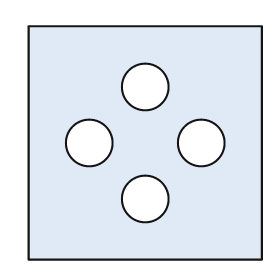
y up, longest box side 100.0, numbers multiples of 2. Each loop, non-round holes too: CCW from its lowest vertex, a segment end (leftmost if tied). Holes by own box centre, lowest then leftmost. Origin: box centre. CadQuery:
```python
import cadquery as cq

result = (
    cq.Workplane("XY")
    .moveTo(-50.0, -50.0)
    .lineTo(50.0, -50.0)
    .lineTo(50.0, 50.0)
    .lineTo(-50.0, 50.0)
    .close()
    .moveTo(0.0, -24.0)
    .circle(10.0)
    .moveTo(-24.0, 0.0)
    .circle(10.0)
    .moveTo(24.0, 0.0)
    .circle(10.0)
    .moveTo(0.0, 24.0)
    .circle(10.0)
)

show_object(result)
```